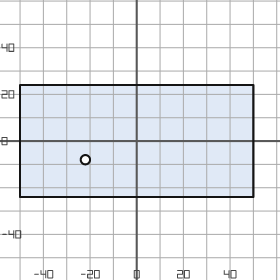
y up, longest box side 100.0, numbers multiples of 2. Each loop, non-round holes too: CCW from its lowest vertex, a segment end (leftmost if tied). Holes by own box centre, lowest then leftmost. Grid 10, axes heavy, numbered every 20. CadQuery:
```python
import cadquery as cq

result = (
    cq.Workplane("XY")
    .moveTo(-50.0, -24.0)
    .lineTo(50.0, -24.0)
    .lineTo(50.0, 24.0)
    .lineTo(-50.0, 24.0)
    .close()
    .moveTo(-22.0, -8.0)
    .circle(2.0)
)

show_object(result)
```